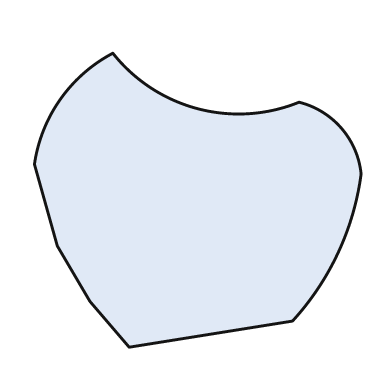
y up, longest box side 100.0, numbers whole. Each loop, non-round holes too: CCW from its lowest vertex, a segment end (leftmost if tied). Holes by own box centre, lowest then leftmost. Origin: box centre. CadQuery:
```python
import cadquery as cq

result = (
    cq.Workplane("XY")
    .moveTo(-21.0, -45.0)
    .lineTo(29.0, -37.0)
    .threePointArc((43.0, -16.0), (50.0, 8.0))
    .threePointArc((44.0, 22.0), (31.0, 30.0))
    .threePointArc((0.0, 28.0), (-26.0, 45.0))
    .threePointArc((-42.0, 31.0), (-50.0, 11.0))
    .lineTo(-43.0, -14.0)
    .lineTo(-33.0, -31.0)
    .close()
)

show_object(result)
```